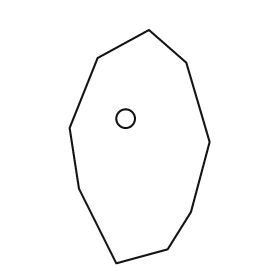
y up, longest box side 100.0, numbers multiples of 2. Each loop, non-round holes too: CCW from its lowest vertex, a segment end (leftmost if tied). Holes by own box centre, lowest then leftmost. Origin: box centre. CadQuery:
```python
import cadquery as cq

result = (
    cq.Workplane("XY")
    .moveTo(-10.0, -50.0)
    .lineTo(12.0, -44.0)
    .lineTo(22.0, -28.0)
    .lineTo(30.0, 2.0)
    .lineTo(20.0, 36.0)
    .lineTo(4.0, 50.0)
    .lineTo(-18.0, 38.0)
    .lineTo(-30.0, 8.0)
    .lineTo(-26.0, -18.0)
    .close()
    .moveTo(-6.0, 12.0)
    .circle(4.0)
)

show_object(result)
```